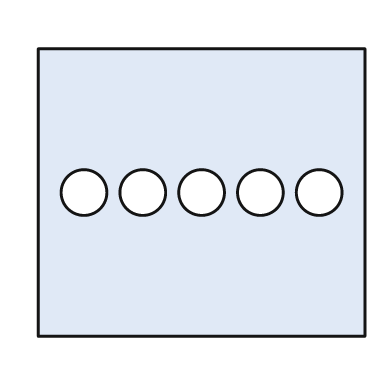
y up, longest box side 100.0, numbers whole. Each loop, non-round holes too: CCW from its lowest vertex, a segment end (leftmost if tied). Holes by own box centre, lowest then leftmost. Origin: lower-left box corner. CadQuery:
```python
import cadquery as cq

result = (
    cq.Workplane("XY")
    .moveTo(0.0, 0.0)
    .lineTo(100.0, 0.0)
    .lineTo(100.0, 88.0)
    .lineTo(0.0, 88.0)
    .close()
    .moveTo(14.0, 44.0)
    .circle(7.0)
    .moveTo(32.0, 44.0)
    .circle(7.0)
    .moveTo(50.0, 44.0)
    .circle(7.0)
    .moveTo(68.0, 44.0)
    .circle(7.0)
    .moveTo(86.0, 44.0)
    .circle(7.0)
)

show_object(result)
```